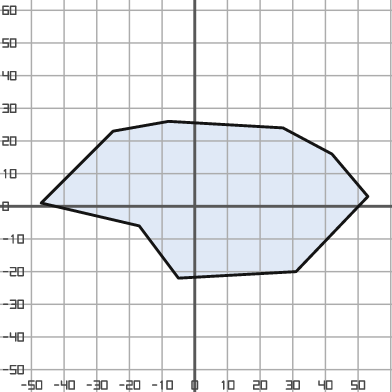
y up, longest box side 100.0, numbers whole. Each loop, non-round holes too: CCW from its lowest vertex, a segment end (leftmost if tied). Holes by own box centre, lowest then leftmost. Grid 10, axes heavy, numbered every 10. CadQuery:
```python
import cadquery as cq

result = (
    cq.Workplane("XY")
    .moveTo(-5.0, -22.0)
    .lineTo(31.0, -20.0)
    .lineTo(53.0, 3.0)
    .lineTo(42.0, 16.0)
    .lineTo(27.0, 24.0)
    .lineTo(-8.0, 26.0)
    .lineTo(-25.0, 23.0)
    .lineTo(-47.0, 1.0)
    .lineTo(-17.0, -6.0)
    .close()
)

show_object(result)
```